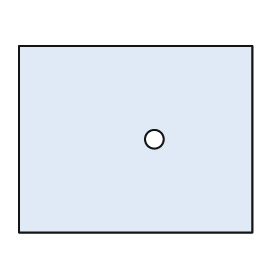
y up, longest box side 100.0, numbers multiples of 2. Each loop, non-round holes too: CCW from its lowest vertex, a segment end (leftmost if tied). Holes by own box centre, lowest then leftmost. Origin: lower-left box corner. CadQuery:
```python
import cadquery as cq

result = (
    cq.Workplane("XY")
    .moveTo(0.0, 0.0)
    .lineTo(100.0, 0.0)
    .lineTo(100.0, 80.0)
    .lineTo(0.0, 80.0)
    .close()
    .moveTo(58.0, 40.0)
    .circle(4.0)
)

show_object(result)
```